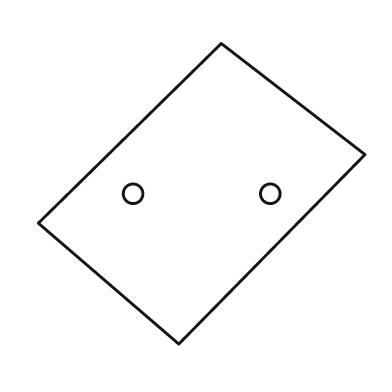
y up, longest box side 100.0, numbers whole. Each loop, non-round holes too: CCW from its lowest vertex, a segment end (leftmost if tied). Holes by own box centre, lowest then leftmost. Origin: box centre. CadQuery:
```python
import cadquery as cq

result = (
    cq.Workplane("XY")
    .moveTo(-7.0, -46.0)
    .lineTo(50.0, 12.0)
    .lineTo(6.0, 46.0)
    .lineTo(-50.0, -9.0)
    .close()
    .moveTo(-21.0, 0.0)
    .circle(3.0)
    .moveTo(21.0, 0.0)
    .circle(3.0)
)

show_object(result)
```